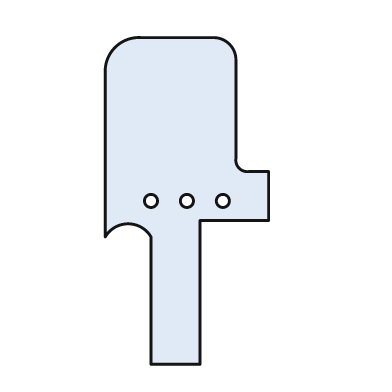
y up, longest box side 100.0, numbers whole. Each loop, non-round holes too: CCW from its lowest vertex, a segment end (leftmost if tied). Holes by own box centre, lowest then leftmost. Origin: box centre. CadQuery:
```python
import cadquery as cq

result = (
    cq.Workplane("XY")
    .moveTo(-11.0, -50.0)
    .lineTo(4.0, -50.0)
    .lineTo(4.0, -6.0)
    .lineTo(25.0, -6.0)
    .lineTo(25.0, 9.0)
    .lineTo(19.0, 9.0)
    .threePointArc((16.0, 10.0), (15.0, 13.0))
    .lineTo(15.0, 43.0)
    .threePointArc((13.0, 48.0), (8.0, 50.0))
    .lineTo(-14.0, 50.0)
    .threePointArc((-22.0, 47.0), (-25.0, 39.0))
    .lineTo(-25.0, -11.0)
    .threePointArc((-18.0, -7.0), (-11.0, -11.0))
    .close()
    .moveTo(-11.0, 0.0)
    .circle(2.0)
    .moveTo(0.0, 0.0)
    .circle(2.0)
    .moveTo(11.0, 0.0)
    .circle(2.0)
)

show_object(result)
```